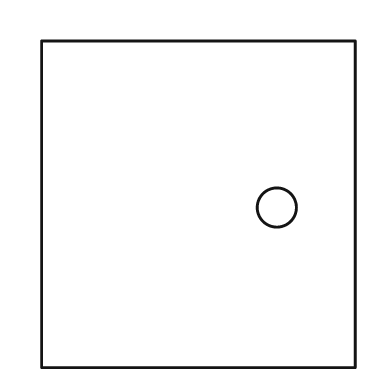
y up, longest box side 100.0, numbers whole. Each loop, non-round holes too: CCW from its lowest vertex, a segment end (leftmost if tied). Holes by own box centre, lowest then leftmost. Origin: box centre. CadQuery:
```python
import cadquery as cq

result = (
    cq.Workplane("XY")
    .moveTo(-48.0, -50.0)
    .lineTo(48.0, -50.0)
    .lineTo(48.0, 50.0)
    .lineTo(-48.0, 50.0)
    .close()
    .moveTo(24.0, -1.0)
    .circle(6.0)
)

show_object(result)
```